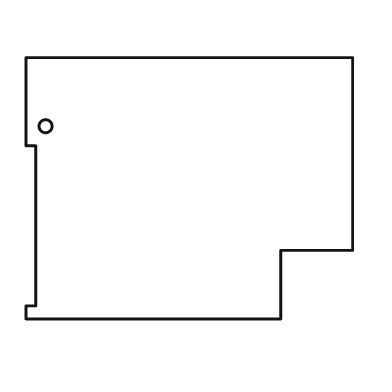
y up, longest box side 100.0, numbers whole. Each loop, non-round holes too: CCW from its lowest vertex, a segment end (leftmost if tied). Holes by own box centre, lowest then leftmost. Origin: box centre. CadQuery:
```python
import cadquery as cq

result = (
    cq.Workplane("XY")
    .moveTo(-50.0, -40.0)
    .lineTo(28.0, -40.0)
    .lineTo(28.0, -19.0)
    .lineTo(50.0, -19.0)
    .lineTo(50.0, 40.0)
    .lineTo(-50.0, 40.0)
    .lineTo(-50.0, 13.0)
    .lineTo(-47.0, 13.0)
    .lineTo(-47.0, -36.0)
    .lineTo(-50.0, -36.0)
    .close()
    .moveTo(-44.0, 19.0)
    .circle(2.0)
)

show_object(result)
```